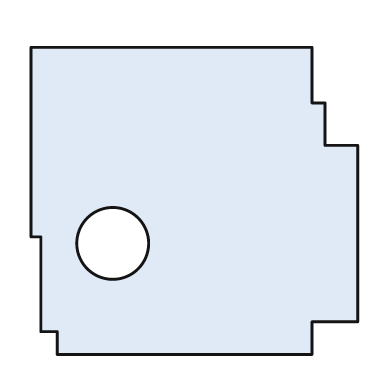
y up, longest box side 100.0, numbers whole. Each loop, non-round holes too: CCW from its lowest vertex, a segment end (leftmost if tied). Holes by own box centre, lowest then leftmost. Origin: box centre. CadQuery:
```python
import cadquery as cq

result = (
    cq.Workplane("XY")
    .moveTo(-42.0, -47.0)
    .lineTo(36.0, -47.0)
    .lineTo(36.0, -37.0)
    .lineTo(50.0, -37.0)
    .lineTo(50.0, 17.0)
    .lineTo(40.0, 17.0)
    .lineTo(40.0, 30.0)
    .lineTo(36.0, 30.0)
    .lineTo(36.0, 47.0)
    .lineTo(-50.0, 47.0)
    .lineTo(-50.0, -11.0)
    .lineTo(-47.0, -11.0)
    .lineTo(-47.0, -40.0)
    .lineTo(-42.0, -40.0)
    .close()
    .moveTo(-25.0, -13.0)
    .circle(11.0)
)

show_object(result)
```